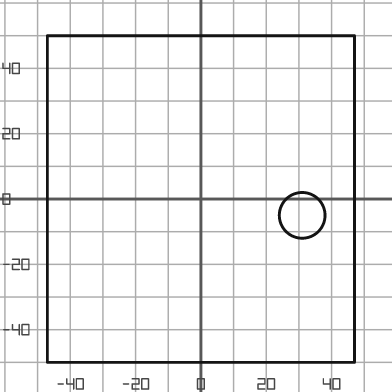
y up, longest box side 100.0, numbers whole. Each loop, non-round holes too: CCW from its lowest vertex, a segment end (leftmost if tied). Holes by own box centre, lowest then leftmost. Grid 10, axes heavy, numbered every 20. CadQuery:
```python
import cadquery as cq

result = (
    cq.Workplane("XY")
    .moveTo(-47.0, -50.0)
    .lineTo(47.0, -50.0)
    .lineTo(47.0, 50.0)
    .lineTo(-47.0, 50.0)
    .close()
    .moveTo(31.0, -5.0)
    .circle(7.0)
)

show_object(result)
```